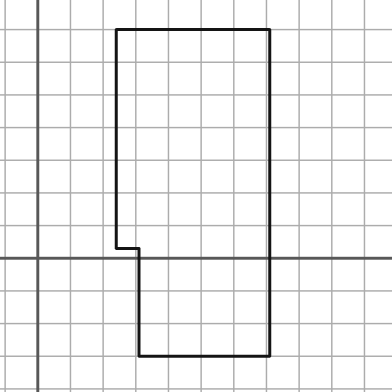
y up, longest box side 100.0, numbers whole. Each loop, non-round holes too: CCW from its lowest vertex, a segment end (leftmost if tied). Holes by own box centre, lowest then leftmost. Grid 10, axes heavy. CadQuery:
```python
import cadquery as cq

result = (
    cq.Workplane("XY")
    .moveTo(31.0, -30.0)
    .lineTo(71.0, -30.0)
    .lineTo(71.0, 70.0)
    .lineTo(24.0, 70.0)
    .lineTo(24.0, 3.0)
    .lineTo(31.0, 3.0)
    .close()
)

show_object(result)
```